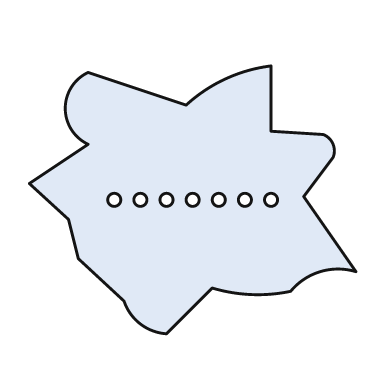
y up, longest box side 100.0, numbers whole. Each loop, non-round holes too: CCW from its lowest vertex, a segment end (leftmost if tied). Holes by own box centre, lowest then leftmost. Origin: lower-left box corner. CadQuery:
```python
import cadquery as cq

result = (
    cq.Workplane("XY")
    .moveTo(42.0, 0.0)
    .lineTo(56.0, 14.0)
    .threePointArc((68.0, 12.0), (80.0, 13.0))
    .threePointArc((89.0, 19.0), (100.0, 19.0))
    .lineTo(84.0, 42.0)
    .lineTo(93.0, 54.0)
    .threePointArc((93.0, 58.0), (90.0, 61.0))
    .lineTo(74.0, 62.0)
    .lineTo(74.0, 82.0)
    .threePointArc((60.0, 78.0), (48.0, 70.0))
    .lineTo(18.0, 80.0)
    .threePointArc((11.0, 69.0), (18.0, 58.0))
    .lineTo(0.0, 46.0)
    .lineTo(12.0, 35.0)
    .lineTo(15.0, 23.0)
    .lineTo(29.0, 10.0)
    .threePointArc((34.0, 3.0), (42.0, 0.0))
    .close()
    .moveTo(26.0, 41.0)
    .circle(2.0)
    .moveTo(34.0, 41.0)
    .circle(2.0)
    .moveTo(42.0, 41.0)
    .circle(2.0)
    .moveTo(50.0, 41.0)
    .circle(2.0)
    .moveTo(58.0, 41.0)
    .circle(2.0)
    .moveTo(66.0, 41.0)
    .circle(2.0)
    .moveTo(74.0, 41.0)
    .circle(2.0)
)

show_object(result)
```